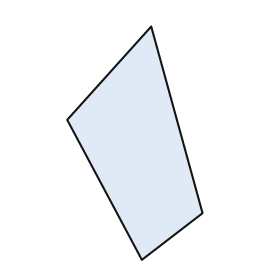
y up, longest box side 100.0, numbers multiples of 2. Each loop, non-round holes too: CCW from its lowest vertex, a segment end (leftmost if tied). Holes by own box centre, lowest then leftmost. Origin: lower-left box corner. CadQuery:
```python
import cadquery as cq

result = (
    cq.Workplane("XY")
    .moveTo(32.0, 0.0)
    .lineTo(58.0, 20.0)
    .lineTo(36.0, 100.0)
    .lineTo(0.0, 60.0)
    .close()
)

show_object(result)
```